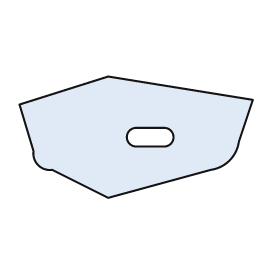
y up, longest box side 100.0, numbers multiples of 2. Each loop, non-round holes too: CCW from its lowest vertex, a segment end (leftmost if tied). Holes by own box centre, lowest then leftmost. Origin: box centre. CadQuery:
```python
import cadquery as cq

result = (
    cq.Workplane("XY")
    .moveTo(-12.0, -26.0)
    .lineTo(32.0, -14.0)
    .threePointArc((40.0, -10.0), (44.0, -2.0))
    .lineTo(50.0, 16.0)
    .lineTo(-12.0, 26.0)
    .lineTo(-50.0, 14.0)
    .lineTo(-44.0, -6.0)
    .threePointArc((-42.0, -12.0), (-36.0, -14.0))
    .close()
    .moveTo(0.0, -4.0)
    .lineTo(12.0, -4.0)
    .threePointArc((16.0, 0.0), (12.0, 4.0))
    .lineTo(0.0, 4.0)
    .threePointArc((-4.0, 0.0), (0.0, -4.0))
    .close()
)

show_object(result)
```